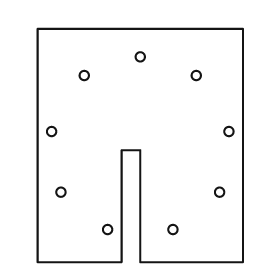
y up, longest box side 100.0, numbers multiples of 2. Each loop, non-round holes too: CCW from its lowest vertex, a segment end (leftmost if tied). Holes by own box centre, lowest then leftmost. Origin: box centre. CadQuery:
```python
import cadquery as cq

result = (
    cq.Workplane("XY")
    .moveTo(-44.0, -50.0)
    .lineTo(-8.0, -50.0)
    .lineTo(-8.0, -2.0)
    .lineTo(0.0, -2.0)
    .lineTo(0.0, -50.0)
    .lineTo(44.0, -50.0)
    .lineTo(44.0, 50.0)
    .lineTo(-44.0, 50.0)
    .close()
    .moveTo(-14.0, -36.0)
    .circle(2.0)
    .moveTo(14.0, -36.0)
    .circle(2.0)
    .moveTo(-34.0, -20.0)
    .circle(2.0)
    .moveTo(34.0, -20.0)
    .circle(2.0)
    .moveTo(-38.0, 6.0)
    .circle(2.0)
    .moveTo(38.0, 6.0)
    .circle(2.0)
    .moveTo(-24.0, 30.0)
    .circle(2.0)
    .moveTo(24.0, 30.0)
    .circle(2.0)
    .moveTo(0.0, 38.0)
    .circle(2.0)
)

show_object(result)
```